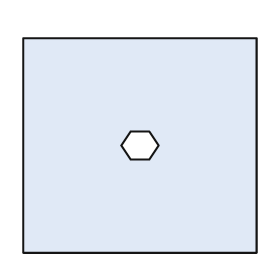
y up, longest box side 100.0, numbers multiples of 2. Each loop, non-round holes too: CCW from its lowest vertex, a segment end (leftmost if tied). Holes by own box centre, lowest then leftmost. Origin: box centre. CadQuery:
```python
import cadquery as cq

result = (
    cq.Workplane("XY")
    .moveTo(-50.0, -46.0)
    .lineTo(50.0, -46.0)
    .lineTo(50.0, 46.0)
    .lineTo(-50.0, 46.0)
    .close()
    .moveTo(-4.0, -6.0)
    .lineTo(4.0, -6.0)
    .lineTo(8.0, 0.0)
    .lineTo(4.0, 6.0)
    .lineTo(-4.0, 6.0)
    .lineTo(-8.0, 0.0)
    .close()
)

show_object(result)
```